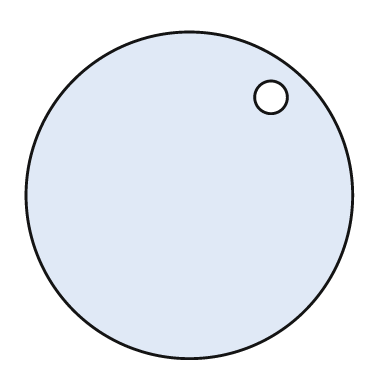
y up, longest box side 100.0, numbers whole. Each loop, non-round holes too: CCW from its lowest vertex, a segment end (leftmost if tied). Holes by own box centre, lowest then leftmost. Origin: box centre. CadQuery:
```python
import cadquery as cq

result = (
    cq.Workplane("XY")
    .moveTo(0.0, 0.0)
    .circle(50.0)
    .moveTo(25.0, 30.0)
    .circle(5.0)
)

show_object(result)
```